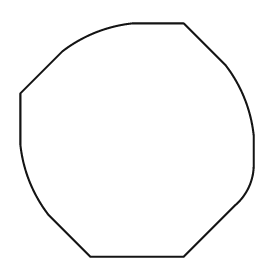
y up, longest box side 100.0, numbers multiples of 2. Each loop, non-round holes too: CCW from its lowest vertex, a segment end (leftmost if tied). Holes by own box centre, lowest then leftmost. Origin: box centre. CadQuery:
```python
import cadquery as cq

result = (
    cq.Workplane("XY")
    .moveTo(-20.0, -50.0)
    .lineTo(20.0, -50.0)
    .lineTo(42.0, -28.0)
    .threePointArc((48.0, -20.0), (50.0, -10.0))
    .lineTo(50.0, 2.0)
    .threePointArc((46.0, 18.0), (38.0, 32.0))
    .lineTo(20.0, 50.0)
    .lineTo(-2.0, 50.0)
    .threePointArc((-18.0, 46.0), (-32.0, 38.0))
    .lineTo(-50.0, 20.0)
    .lineTo(-50.0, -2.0)
    .threePointArc((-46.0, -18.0), (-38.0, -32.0))
    .close()
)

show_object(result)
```